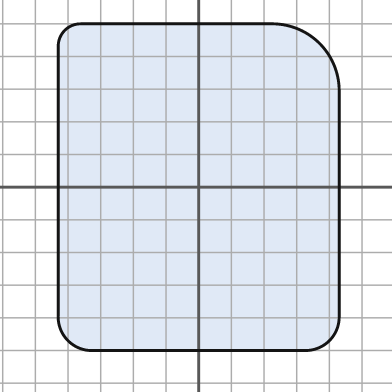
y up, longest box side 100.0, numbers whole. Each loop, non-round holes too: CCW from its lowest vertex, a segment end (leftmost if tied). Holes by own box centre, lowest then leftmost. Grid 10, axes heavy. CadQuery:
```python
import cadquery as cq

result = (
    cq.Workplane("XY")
    .moveTo(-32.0, -50.0)
    .lineTo(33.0, -50.0)
    .threePointArc((40.0, -47.0), (43.0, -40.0))
    .lineTo(43.0, 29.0)
    .threePointArc((37.0, 44.0), (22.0, 50.0))
    .lineTo(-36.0, 50.0)
    .threePointArc((-41.0, 48.0), (-43.0, 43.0))
    .lineTo(-43.0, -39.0)
    .threePointArc((-40.0, -47.0), (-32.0, -50.0))
    .close()
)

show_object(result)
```